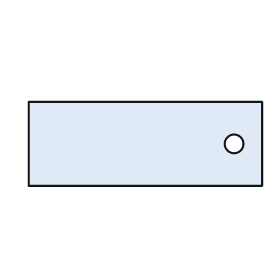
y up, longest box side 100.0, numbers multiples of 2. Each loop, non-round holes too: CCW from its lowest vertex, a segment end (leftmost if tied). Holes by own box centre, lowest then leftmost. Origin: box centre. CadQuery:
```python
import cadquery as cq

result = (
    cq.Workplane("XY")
    .moveTo(-50.0, -18.0)
    .lineTo(50.0, -18.0)
    .lineTo(50.0, 18.0)
    .lineTo(-50.0, 18.0)
    .close()
    .moveTo(38.0, 0.0)
    .circle(4.0)
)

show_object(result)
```